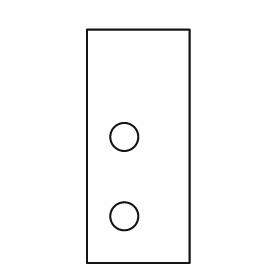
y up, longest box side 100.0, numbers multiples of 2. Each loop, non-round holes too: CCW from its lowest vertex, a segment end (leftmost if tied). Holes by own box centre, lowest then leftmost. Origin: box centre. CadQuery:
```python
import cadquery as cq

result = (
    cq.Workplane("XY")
    .moveTo(-22.0, -50.0)
    .lineTo(22.0, -50.0)
    .lineTo(22.0, 50.0)
    .lineTo(-22.0, 50.0)
    .close()
    .moveTo(-6.0, -30.0)
    .circle(6.0)
    .moveTo(-6.0, 4.0)
    .circle(6.0)
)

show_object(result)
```